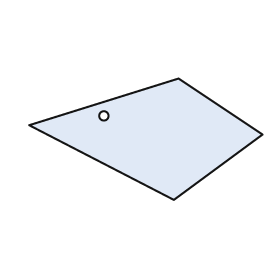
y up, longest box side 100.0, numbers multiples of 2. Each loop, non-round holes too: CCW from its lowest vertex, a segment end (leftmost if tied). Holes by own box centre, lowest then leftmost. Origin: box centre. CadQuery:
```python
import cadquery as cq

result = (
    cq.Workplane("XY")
    .moveTo(12.0, -26.0)
    .lineTo(50.0, 2.0)
    .lineTo(14.0, 26.0)
    .lineTo(-50.0, 6.0)
    .close()
    .moveTo(-18.0, 10.0)
    .circle(2.0)
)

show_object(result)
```